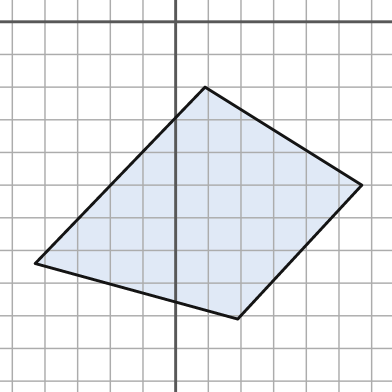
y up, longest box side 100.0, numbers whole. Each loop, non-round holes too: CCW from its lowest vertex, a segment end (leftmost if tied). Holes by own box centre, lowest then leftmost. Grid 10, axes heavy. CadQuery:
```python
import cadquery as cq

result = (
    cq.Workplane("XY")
    .moveTo(19.0, -91.0)
    .lineTo(57.0, -50.0)
    .lineTo(9.0, -20.0)
    .lineTo(-43.0, -74.0)
    .close()
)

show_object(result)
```